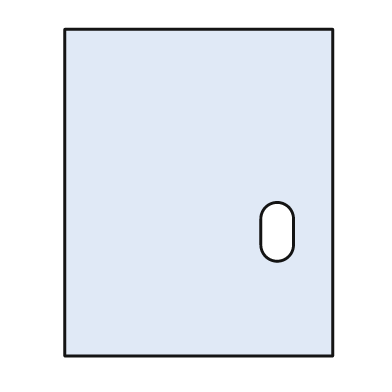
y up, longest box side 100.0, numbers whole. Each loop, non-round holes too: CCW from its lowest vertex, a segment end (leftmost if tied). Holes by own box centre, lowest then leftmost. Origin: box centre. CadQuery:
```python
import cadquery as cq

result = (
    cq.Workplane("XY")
    .moveTo(-41.0, -50.0)
    .lineTo(41.0, -50.0)
    .lineTo(41.0, 50.0)
    .lineTo(-41.0, 50.0)
    .close()
    .moveTo(19.0, -16.0)
    .threePointArc((24.0, -21.0), (29.0, -16.0))
    .lineTo(29.0, -8.0)
    .threePointArc((24.0, -3.0), (19.0, -8.0))
    .close()
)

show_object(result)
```